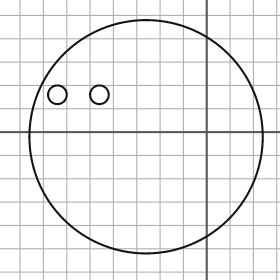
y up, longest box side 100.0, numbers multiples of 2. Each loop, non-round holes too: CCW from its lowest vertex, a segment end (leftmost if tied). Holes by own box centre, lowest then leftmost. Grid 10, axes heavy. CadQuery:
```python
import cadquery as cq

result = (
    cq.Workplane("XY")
    .moveTo(-26.0, -2.0)
    .circle(50.0)
    .moveTo(-64.0, 16.0)
    .circle(4.0)
    .moveTo(-46.0, 16.0)
    .circle(4.0)
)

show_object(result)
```